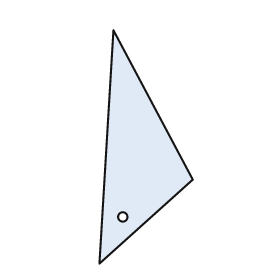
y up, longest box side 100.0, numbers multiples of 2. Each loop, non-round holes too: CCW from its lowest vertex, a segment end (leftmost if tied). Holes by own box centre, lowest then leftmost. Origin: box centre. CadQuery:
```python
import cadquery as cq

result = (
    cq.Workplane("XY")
    .moveTo(-20.0, -50.0)
    .lineTo(20.0, -14.0)
    .lineTo(-14.0, 50.0)
    .close()
    .moveTo(-10.0, -30.0)
    .circle(2.0)
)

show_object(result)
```